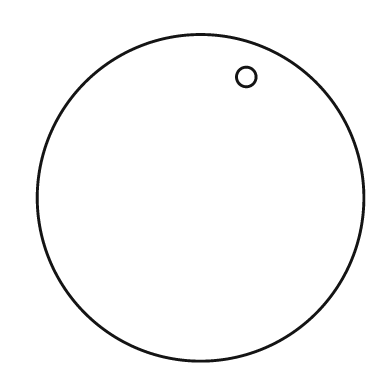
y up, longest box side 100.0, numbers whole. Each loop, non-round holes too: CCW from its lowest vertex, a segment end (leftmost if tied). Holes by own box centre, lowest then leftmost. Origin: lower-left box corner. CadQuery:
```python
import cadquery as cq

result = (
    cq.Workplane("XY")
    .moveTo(50.0, 50.0)
    .circle(50.0)
    .moveTo(64.0, 87.0)
    .circle(3.0)
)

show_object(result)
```